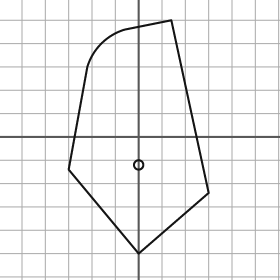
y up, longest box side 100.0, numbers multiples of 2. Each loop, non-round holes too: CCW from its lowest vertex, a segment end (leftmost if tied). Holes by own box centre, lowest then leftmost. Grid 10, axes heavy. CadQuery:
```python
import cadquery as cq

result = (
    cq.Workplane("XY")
    .moveTo(0.0, -50.0)
    .lineTo(30.0, -24.0)
    .lineTo(14.0, 50.0)
    .lineTo(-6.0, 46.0)
    .threePointArc((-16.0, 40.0), (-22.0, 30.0))
    .lineTo(-30.0, -14.0)
    .close()
    .moveTo(0.0, -12.0)
    .circle(2.0)
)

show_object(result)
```